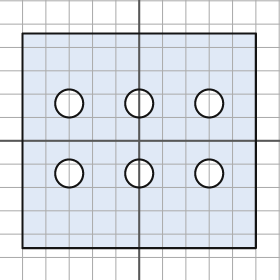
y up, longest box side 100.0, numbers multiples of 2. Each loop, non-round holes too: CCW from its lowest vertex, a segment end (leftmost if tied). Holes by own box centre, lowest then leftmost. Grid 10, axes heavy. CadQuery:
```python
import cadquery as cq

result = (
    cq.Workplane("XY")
    .moveTo(-50.0, -46.0)
    .lineTo(50.0, -46.0)
    .lineTo(50.0, 46.0)
    .lineTo(-50.0, 46.0)
    .close()
    .moveTo(-30.0, -14.0)
    .circle(6.0)
    .moveTo(0.0, -14.0)
    .circle(6.0)
    .moveTo(30.0, -14.0)
    .circle(6.0)
    .moveTo(-30.0, 16.0)
    .circle(6.0)
    .moveTo(0.0, 16.0)
    .circle(6.0)
    .moveTo(30.0, 16.0)
    .circle(6.0)
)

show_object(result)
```